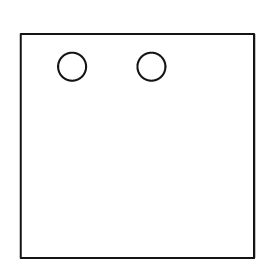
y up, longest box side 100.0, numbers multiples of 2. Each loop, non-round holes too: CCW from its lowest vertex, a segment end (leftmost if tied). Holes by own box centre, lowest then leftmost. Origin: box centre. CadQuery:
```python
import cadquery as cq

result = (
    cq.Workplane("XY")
    .moveTo(-50.0, -48.0)
    .lineTo(50.0, -48.0)
    .lineTo(50.0, 48.0)
    .lineTo(-50.0, 48.0)
    .close()
    .moveTo(-28.0, 34.0)
    .circle(6.0)
    .moveTo(6.0, 34.0)
    .circle(6.0)
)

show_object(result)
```